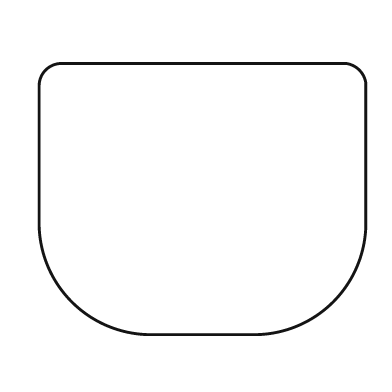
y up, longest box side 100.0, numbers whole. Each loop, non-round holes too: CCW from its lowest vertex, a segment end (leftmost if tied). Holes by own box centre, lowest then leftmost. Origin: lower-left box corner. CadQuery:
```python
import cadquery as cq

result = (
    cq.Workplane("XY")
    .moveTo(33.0, 0.0)
    .lineTo(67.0, 0.0)
    .threePointArc((90.0, 10.0), (100.0, 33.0))
    .lineTo(100.0, 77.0)
    .threePointArc((98.0, 81.0), (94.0, 83.0))
    .lineTo(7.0, 83.0)
    .threePointArc((2.0, 81.0), (0.0, 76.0))
    .lineTo(0.0, 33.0)
    .threePointArc((10.0, 10.0), (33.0, 0.0))
    .close()
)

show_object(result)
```